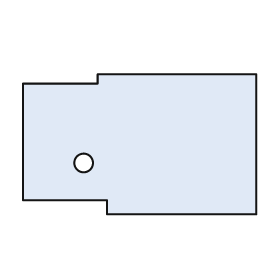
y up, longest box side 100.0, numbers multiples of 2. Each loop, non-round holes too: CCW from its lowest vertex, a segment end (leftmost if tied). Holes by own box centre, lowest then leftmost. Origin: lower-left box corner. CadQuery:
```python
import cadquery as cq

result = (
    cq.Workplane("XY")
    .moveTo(36.0, 0.0)
    .lineTo(100.0, 0.0)
    .lineTo(100.0, 60.0)
    .lineTo(32.0, 60.0)
    .lineTo(32.0, 56.0)
    .lineTo(0.0, 56.0)
    .lineTo(0.0, 6.0)
    .lineTo(36.0, 6.0)
    .close()
    .moveTo(26.0, 22.0)
    .circle(4.0)
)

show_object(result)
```